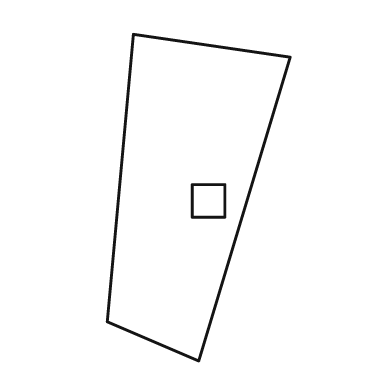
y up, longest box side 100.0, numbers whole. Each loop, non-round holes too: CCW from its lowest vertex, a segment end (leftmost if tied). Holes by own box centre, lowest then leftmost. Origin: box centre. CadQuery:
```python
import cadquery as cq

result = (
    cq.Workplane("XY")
    .moveTo(0.0, -50.0)
    .lineTo(28.0, 43.0)
    .lineTo(-20.0, 50.0)
    .lineTo(-28.0, -38.0)
    .close()
    .moveTo(-2.0, -6.0)
    .lineTo(8.0, -6.0)
    .lineTo(8.0, 4.0)
    .lineTo(-2.0, 4.0)
    .close()
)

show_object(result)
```